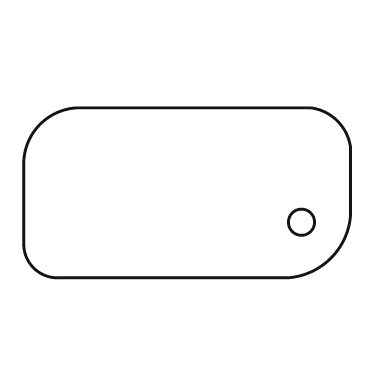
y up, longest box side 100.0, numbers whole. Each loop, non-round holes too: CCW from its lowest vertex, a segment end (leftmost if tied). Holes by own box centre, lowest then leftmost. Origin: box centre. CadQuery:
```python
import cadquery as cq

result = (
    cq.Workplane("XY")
    .moveTo(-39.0, -26.0)
    .lineTo(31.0, -26.0)
    .threePointArc((44.0, -20.0), (50.0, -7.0))
    .lineTo(50.0, 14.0)
    .threePointArc((46.0, 22.0), (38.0, 26.0))
    .lineTo(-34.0, 26.0)
    .threePointArc((-45.0, 21.0), (-50.0, 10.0))
    .lineTo(-50.0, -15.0)
    .threePointArc((-47.0, -23.0), (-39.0, -26.0))
    .close()
    .moveTo(35.0, -9.0)
    .circle(4.0)
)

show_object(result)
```